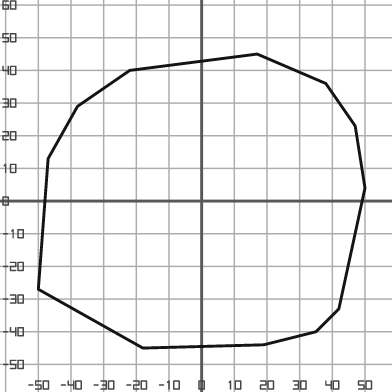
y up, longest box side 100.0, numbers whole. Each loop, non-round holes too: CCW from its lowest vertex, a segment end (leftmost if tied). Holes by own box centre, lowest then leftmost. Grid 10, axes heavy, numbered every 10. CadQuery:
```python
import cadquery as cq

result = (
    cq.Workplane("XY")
    .moveTo(-18.0, -45.0)
    .lineTo(19.0, -44.0)
    .lineTo(35.0, -40.0)
    .lineTo(42.0, -33.0)
    .lineTo(50.0, 4.0)
    .lineTo(47.0, 23.0)
    .lineTo(38.0, 36.0)
    .lineTo(17.0, 45.0)
    .lineTo(-22.0, 40.0)
    .lineTo(-38.0, 29.0)
    .lineTo(-47.0, 13.0)
    .lineTo(-50.0, -27.0)
    .close()
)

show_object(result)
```